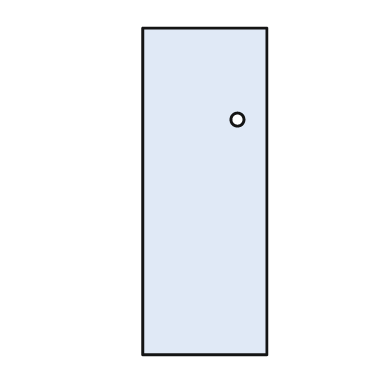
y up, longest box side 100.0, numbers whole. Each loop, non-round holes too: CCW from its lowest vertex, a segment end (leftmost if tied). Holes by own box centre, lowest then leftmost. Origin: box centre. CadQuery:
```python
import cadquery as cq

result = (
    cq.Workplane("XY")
    .moveTo(-19.0, -50.0)
    .lineTo(19.0, -50.0)
    .lineTo(19.0, 50.0)
    .lineTo(-19.0, 50.0)
    .close()
    .moveTo(10.0, 22.0)
    .circle(2.0)
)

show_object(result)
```